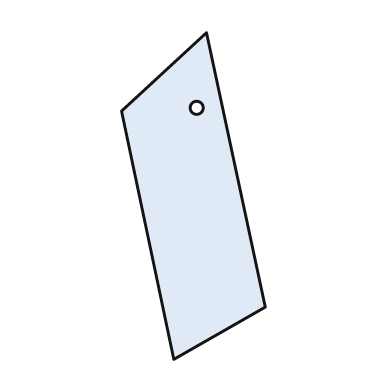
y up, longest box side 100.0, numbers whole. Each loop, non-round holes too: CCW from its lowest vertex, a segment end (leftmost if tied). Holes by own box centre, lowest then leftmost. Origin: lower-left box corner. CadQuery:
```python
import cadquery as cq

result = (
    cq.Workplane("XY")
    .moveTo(16.0, 0.0)
    .lineTo(44.0, 16.0)
    .lineTo(26.0, 100.0)
    .lineTo(0.0, 76.0)
    .close()
    .moveTo(23.0, 77.0)
    .circle(2.0)
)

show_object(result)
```